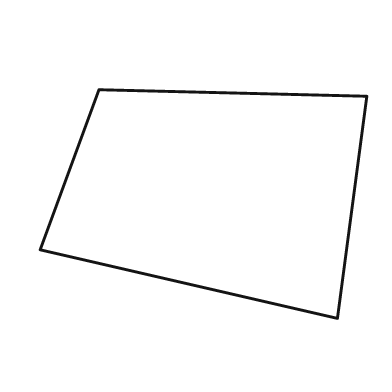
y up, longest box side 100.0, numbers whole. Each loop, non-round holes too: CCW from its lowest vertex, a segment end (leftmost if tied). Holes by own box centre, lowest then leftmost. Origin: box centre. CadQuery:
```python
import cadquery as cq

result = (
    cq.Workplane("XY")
    .moveTo(41.0, -35.0)
    .lineTo(50.0, 33.0)
    .lineTo(-32.0, 35.0)
    .lineTo(-50.0, -14.0)
    .close()
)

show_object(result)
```